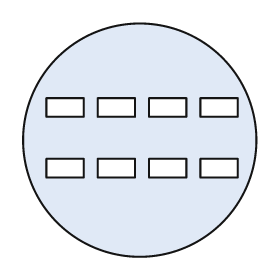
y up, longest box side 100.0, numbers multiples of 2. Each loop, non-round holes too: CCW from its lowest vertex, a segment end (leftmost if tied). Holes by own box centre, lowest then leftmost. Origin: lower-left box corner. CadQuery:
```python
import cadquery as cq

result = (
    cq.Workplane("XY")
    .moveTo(50.0, 50.0)
    .circle(50.0)
    .moveTo(10.0, 34.0)
    .lineTo(26.0, 34.0)
    .lineTo(26.0, 42.0)
    .lineTo(10.0, 42.0)
    .close()
    .moveTo(32.0, 34.0)
    .lineTo(48.0, 34.0)
    .lineTo(48.0, 42.0)
    .lineTo(32.0, 42.0)
    .close()
    .moveTo(54.0, 34.0)
    .lineTo(70.0, 34.0)
    .lineTo(70.0, 42.0)
    .lineTo(54.0, 42.0)
    .close()
    .moveTo(76.0, 34.0)
    .lineTo(92.0, 34.0)
    .lineTo(92.0, 42.0)
    .lineTo(76.0, 42.0)
    .close()
    .moveTo(10.0, 60.0)
    .lineTo(26.0, 60.0)
    .lineTo(26.0, 68.0)
    .lineTo(10.0, 68.0)
    .close()
    .moveTo(32.0, 60.0)
    .lineTo(48.0, 60.0)
    .lineTo(48.0, 68.0)
    .lineTo(32.0, 68.0)
    .close()
    .moveTo(54.0, 60.0)
    .lineTo(70.0, 60.0)
    .lineTo(70.0, 68.0)
    .lineTo(54.0, 68.0)
    .close()
    .moveTo(76.0, 60.0)
    .lineTo(92.0, 60.0)
    .lineTo(92.0, 68.0)
    .lineTo(76.0, 68.0)
    .close()
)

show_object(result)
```